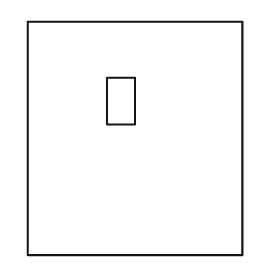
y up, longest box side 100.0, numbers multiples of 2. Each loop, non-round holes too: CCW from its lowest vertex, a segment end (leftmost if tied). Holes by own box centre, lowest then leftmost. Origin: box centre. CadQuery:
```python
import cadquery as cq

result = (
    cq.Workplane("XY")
    .moveTo(-46.0, -50.0)
    .lineTo(46.0, -50.0)
    .lineTo(46.0, 50.0)
    .lineTo(-46.0, 50.0)
    .close()
    .moveTo(-12.0, 6.0)
    .lineTo(0.0, 6.0)
    .lineTo(0.0, 26.0)
    .lineTo(-12.0, 26.0)
    .close()
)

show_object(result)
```